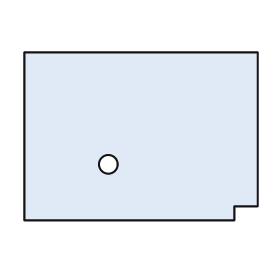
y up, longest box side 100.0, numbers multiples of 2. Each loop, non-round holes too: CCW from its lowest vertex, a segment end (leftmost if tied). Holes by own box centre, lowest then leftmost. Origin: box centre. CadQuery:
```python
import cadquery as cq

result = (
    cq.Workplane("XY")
    .moveTo(-50.0, -36.0)
    .lineTo(40.0, -36.0)
    .lineTo(40.0, -30.0)
    .lineTo(50.0, -30.0)
    .lineTo(50.0, 36.0)
    .lineTo(-50.0, 36.0)
    .close()
    .moveTo(-14.0, -12.0)
    .circle(4.0)
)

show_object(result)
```